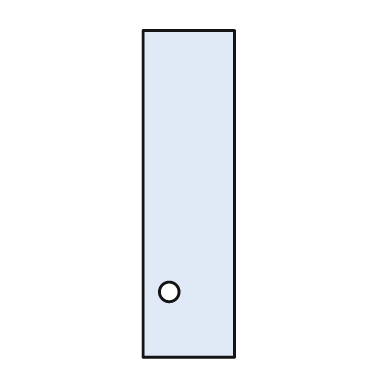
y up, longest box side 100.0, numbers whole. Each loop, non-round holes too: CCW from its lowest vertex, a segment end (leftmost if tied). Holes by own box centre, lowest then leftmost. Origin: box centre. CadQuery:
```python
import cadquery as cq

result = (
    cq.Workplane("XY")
    .moveTo(-14.0, -50.0)
    .lineTo(14.0, -50.0)
    .lineTo(14.0, 50.0)
    .lineTo(-14.0, 50.0)
    .close()
    .moveTo(-6.0, -30.0)
    .circle(3.0)
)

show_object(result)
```